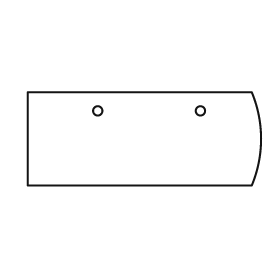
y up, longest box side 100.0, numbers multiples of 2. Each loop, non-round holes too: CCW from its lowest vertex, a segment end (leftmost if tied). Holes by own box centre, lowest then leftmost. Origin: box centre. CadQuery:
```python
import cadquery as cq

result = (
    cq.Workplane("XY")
    .moveTo(-50.0, -20.0)
    .lineTo(46.0, -20.0)
    .threePointArc((50.0, 0.0), (46.0, 20.0))
    .lineTo(-50.0, 20.0)
    .close()
    .moveTo(-20.0, 12.0)
    .circle(2.0)
    .moveTo(24.0, 12.0)
    .circle(2.0)
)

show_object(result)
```